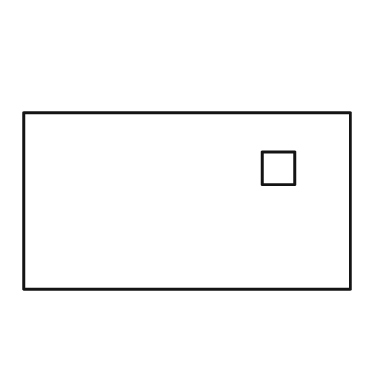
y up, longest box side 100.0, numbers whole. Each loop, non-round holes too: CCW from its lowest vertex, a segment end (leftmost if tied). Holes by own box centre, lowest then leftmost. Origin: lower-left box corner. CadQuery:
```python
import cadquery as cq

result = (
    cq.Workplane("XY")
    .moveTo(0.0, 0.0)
    .lineTo(100.0, 0.0)
    .lineTo(100.0, 54.0)
    .lineTo(0.0, 54.0)
    .close()
    .moveTo(73.0, 32.0)
    .lineTo(83.0, 32.0)
    .lineTo(83.0, 42.0)
    .lineTo(73.0, 42.0)
    .close()
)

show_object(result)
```